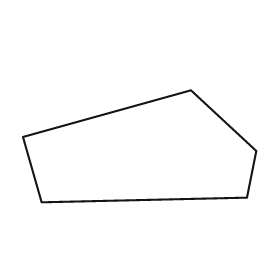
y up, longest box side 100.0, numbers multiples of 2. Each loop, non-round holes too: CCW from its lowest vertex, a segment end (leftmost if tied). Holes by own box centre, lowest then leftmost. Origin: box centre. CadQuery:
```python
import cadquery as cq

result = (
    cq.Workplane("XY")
    .moveTo(-42.0, -24.0)
    .lineTo(46.0, -22.0)
    .lineTo(50.0, -2.0)
    .lineTo(22.0, 24.0)
    .lineTo(-50.0, 4.0)
    .close()
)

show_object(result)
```